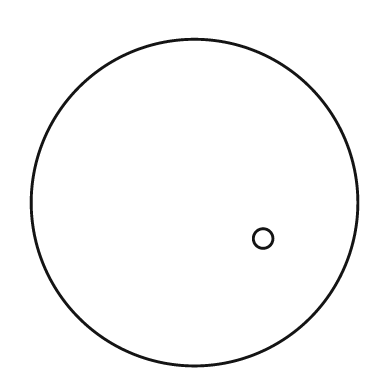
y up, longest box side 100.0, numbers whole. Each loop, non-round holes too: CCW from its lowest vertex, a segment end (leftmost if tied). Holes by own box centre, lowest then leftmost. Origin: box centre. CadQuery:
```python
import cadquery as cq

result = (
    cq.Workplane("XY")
    .moveTo(0.0, 0.0)
    .circle(50.0)
    .moveTo(21.0, -11.0)
    .circle(3.0)
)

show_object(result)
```